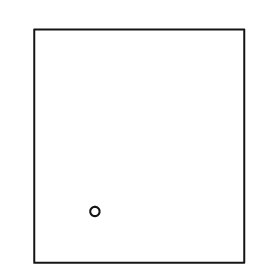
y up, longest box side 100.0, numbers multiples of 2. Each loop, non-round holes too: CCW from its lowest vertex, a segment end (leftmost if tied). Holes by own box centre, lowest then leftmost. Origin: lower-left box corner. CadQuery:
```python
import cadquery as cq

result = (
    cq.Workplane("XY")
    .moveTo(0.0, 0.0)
    .lineTo(90.0, 0.0)
    .lineTo(90.0, 100.0)
    .lineTo(0.0, 100.0)
    .close()
    .moveTo(26.0, 22.0)
    .circle(2.0)
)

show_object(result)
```